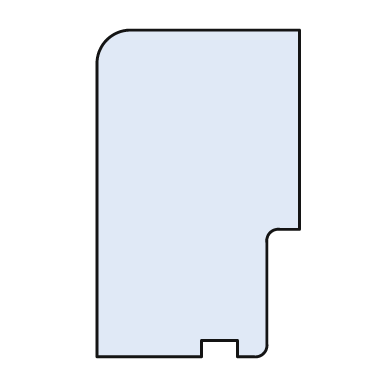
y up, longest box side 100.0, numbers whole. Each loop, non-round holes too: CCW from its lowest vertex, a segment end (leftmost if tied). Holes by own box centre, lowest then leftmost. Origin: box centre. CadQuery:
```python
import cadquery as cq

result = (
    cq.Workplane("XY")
    .moveTo(-31.0, -50.0)
    .lineTo(1.0, -50.0)
    .lineTo(1.0, -45.0)
    .lineTo(12.0, -45.0)
    .lineTo(12.0, -50.0)
    .lineTo(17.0, -50.0)
    .threePointArc((20.0, -49.0), (21.0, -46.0))
    .lineTo(21.0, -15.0)
    .threePointArc((22.0, -12.0), (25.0, -11.0))
    .lineTo(31.0, -11.0)
    .lineTo(31.0, 50.0)
    .lineTo(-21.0, 50.0)
    .threePointArc((-28.0, 47.0), (-31.0, 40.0))
    .close()
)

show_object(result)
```